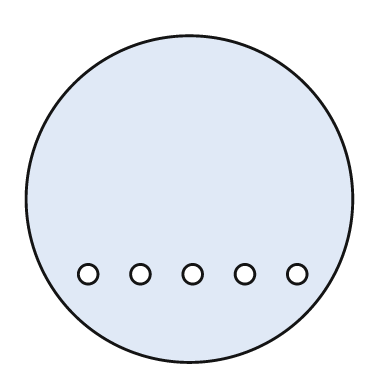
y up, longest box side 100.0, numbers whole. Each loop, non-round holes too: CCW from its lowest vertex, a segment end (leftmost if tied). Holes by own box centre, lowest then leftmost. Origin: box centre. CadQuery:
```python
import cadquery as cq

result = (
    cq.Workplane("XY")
    .moveTo(0.0, 0.0)
    .circle(50.0)
    .moveTo(-31.0, -23.0)
    .circle(3.0)
    .moveTo(-15.0, -23.0)
    .circle(3.0)
    .moveTo(1.0, -23.0)
    .circle(3.0)
    .moveTo(17.0, -23.0)
    .circle(3.0)
    .moveTo(33.0, -23.0)
    .circle(3.0)
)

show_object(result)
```